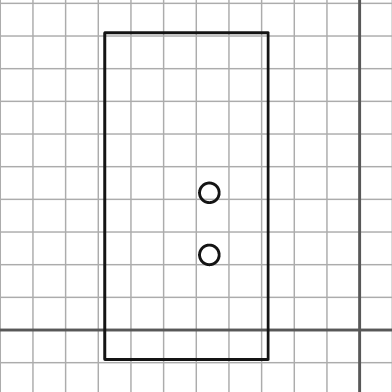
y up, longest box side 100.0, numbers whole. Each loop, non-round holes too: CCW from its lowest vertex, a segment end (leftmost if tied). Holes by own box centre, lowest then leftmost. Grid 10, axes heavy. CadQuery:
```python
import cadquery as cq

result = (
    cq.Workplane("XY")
    .moveTo(-78.0, -9.0)
    .lineTo(-28.0, -9.0)
    .lineTo(-28.0, 91.0)
    .lineTo(-78.0, 91.0)
    .close()
    .moveTo(-46.0, 23.0)
    .circle(3.0)
    .moveTo(-46.0, 42.0)
    .circle(3.0)
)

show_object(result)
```